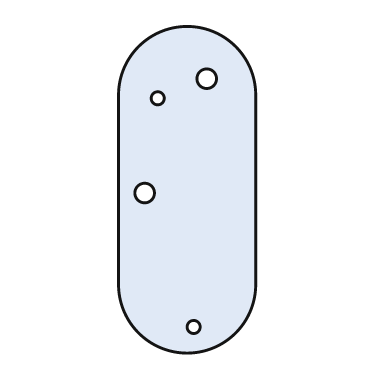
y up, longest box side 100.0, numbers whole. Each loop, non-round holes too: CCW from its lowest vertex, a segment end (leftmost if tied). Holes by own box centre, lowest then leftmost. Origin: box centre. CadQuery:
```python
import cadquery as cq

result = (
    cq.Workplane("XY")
    .moveTo(-21.0, -29.0)
    .threePointArc((0.0, -50.0), (21.0, -29.0))
    .lineTo(21.0, 29.0)
    .threePointArc((0.0, 50.0), (-21.0, 29.0))
    .close()
    .moveTo(2.0, -42.0)
    .circle(2.0)
    .moveTo(-13.0, -1.0)
    .circle(3.0)
    .moveTo(-9.0, 28.0)
    .circle(2.0)
    .moveTo(6.0, 34.0)
    .circle(3.0)
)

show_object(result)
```